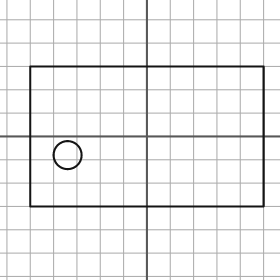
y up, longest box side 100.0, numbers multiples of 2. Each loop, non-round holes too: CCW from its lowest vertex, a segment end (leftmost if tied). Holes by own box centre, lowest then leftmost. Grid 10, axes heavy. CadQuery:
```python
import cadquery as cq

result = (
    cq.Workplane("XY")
    .moveTo(-50.0, -30.0)
    .lineTo(50.0, -30.0)
    .lineTo(50.0, 30.0)
    .lineTo(-50.0, 30.0)
    .close()
    .moveTo(-34.0, -8.0)
    .circle(6.0)
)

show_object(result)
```